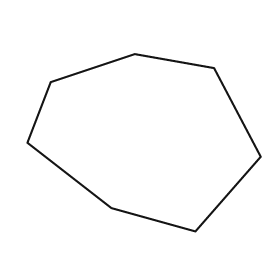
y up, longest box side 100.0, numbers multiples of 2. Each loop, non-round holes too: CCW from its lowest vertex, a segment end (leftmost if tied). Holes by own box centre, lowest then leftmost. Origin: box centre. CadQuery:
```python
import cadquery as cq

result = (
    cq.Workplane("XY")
    .moveTo(22.0, -38.0)
    .lineTo(50.0, -6.0)
    .lineTo(30.0, 32.0)
    .lineTo(-4.0, 38.0)
    .lineTo(-40.0, 26.0)
    .lineTo(-50.0, 0.0)
    .lineTo(-14.0, -28.0)
    .close()
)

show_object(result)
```